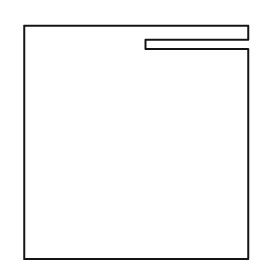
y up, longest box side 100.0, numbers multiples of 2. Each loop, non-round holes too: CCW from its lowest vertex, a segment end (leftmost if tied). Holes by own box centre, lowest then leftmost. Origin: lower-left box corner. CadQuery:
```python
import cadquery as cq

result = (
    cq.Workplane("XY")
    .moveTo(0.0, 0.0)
    .lineTo(96.0, 0.0)
    .lineTo(96.0, 90.0)
    .lineTo(52.0, 90.0)
    .lineTo(52.0, 94.0)
    .lineTo(96.0, 94.0)
    .lineTo(96.0, 100.0)
    .lineTo(0.0, 100.0)
    .close()
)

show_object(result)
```